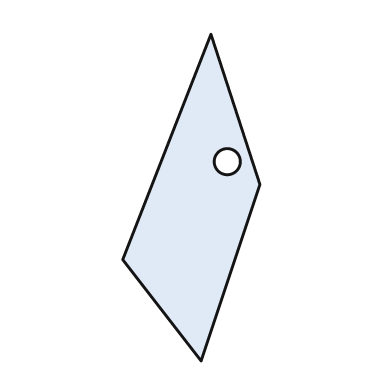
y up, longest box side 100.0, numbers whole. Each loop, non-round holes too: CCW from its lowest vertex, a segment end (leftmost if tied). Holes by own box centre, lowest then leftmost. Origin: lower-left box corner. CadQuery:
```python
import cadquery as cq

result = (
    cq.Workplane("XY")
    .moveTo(24.0, 0.0)
    .lineTo(42.0, 54.0)
    .lineTo(27.0, 100.0)
    .lineTo(0.0, 31.0)
    .close()
    .moveTo(32.0, 61.0)
    .circle(4.0)
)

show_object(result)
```